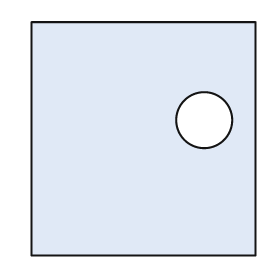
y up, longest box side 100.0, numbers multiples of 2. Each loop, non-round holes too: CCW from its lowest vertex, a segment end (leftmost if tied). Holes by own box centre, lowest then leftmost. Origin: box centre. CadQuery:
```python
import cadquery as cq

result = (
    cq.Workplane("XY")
    .moveTo(-48.0, -50.0)
    .lineTo(48.0, -50.0)
    .lineTo(48.0, 50.0)
    .lineTo(-48.0, 50.0)
    .close()
    .moveTo(26.0, 8.0)
    .circle(12.0)
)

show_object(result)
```